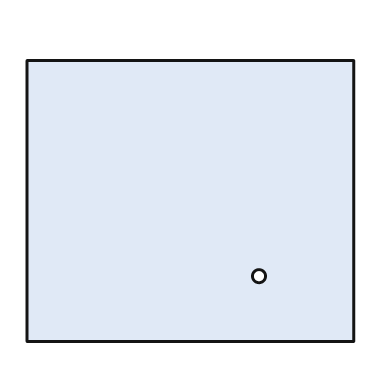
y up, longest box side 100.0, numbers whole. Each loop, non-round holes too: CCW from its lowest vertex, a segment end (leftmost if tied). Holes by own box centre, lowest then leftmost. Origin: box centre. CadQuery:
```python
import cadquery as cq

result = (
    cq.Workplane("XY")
    .moveTo(-50.0, -43.0)
    .lineTo(50.0, -43.0)
    .lineTo(50.0, 43.0)
    .lineTo(-50.0, 43.0)
    .close()
    .moveTo(21.0, -23.0)
    .circle(2.0)
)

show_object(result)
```